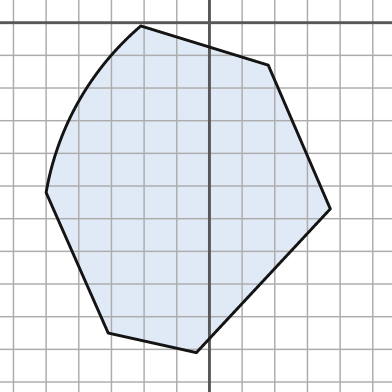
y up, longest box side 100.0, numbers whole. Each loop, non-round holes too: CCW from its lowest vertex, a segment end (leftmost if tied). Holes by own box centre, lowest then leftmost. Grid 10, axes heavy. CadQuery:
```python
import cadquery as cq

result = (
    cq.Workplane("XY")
    .moveTo(-4.0, -101.0)
    .lineTo(37.0, -57.0)
    .lineTo(18.0, -13.0)
    .lineTo(-21.0, -1.0)
    .threePointArc((-40.0, -24.0), (-50.0, -52.0))
    .lineTo(-31.0, -95.0)
    .close()
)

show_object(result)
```